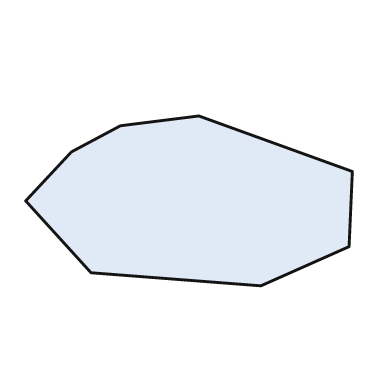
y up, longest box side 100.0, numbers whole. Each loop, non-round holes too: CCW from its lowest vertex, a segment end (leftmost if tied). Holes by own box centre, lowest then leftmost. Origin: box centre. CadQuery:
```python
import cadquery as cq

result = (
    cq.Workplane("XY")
    .moveTo(22.0, -26.0)
    .lineTo(49.0, -14.0)
    .lineTo(50.0, 9.0)
    .lineTo(3.0, 26.0)
    .lineTo(-21.0, 23.0)
    .lineTo(-36.0, 15.0)
    .lineTo(-50.0, 0.0)
    .lineTo(-30.0, -22.0)
    .close()
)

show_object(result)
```